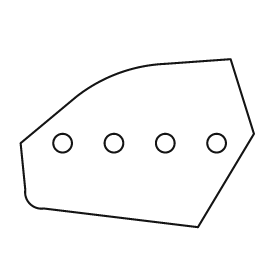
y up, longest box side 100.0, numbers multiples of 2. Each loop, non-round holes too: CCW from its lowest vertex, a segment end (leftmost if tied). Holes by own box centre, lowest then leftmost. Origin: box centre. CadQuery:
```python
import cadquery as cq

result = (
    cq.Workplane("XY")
    .moveTo(26.0, -36.0)
    .lineTo(50.0, 4.0)
    .lineTo(40.0, 36.0)
    .lineTo(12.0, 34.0)
    .threePointArc((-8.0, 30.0), (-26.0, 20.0))
    .lineTo(-50.0, 0.0)
    .lineTo(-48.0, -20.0)
    .threePointArc((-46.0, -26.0), (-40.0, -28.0))
    .close()
    .moveTo(-32.0, 0.0)
    .circle(4.0)
    .moveTo(-10.0, 0.0)
    .circle(4.0)
    .moveTo(12.0, 0.0)
    .circle(4.0)
    .moveTo(34.0, 0.0)
    .circle(4.0)
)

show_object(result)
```